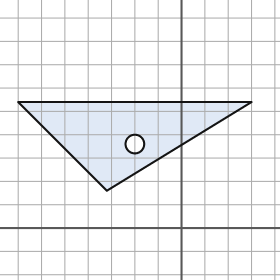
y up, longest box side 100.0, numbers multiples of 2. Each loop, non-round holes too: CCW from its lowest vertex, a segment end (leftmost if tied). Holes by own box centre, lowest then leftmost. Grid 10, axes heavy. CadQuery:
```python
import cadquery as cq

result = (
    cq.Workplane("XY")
    .moveTo(-32.0, 16.0)
    .lineTo(30.0, 54.0)
    .lineTo(-70.0, 54.0)
    .close()
    .moveTo(-20.0, 36.0)
    .circle(4.0)
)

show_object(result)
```